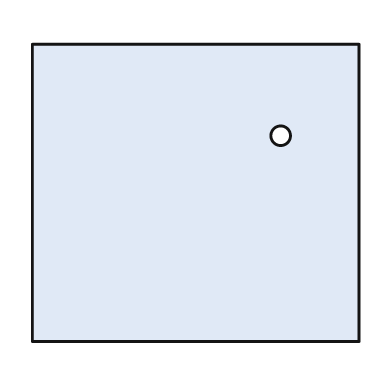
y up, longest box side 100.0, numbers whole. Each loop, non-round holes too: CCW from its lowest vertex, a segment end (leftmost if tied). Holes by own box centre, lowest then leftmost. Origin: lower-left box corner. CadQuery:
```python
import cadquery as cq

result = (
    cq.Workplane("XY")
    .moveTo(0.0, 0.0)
    .lineTo(100.0, 0.0)
    .lineTo(100.0, 91.0)
    .lineTo(0.0, 91.0)
    .close()
    .moveTo(76.0, 63.0)
    .circle(3.0)
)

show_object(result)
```